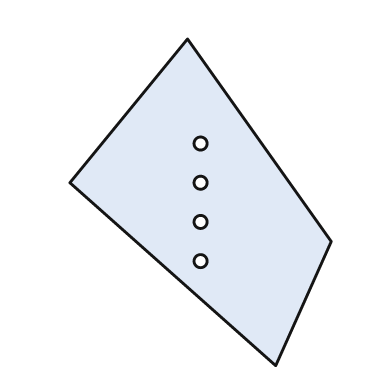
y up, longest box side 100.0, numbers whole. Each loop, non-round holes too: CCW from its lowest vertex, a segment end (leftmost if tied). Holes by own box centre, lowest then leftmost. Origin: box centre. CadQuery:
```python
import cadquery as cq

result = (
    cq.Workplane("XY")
    .moveTo(23.0, -50.0)
    .lineTo(40.0, -12.0)
    .lineTo(-4.0, 50.0)
    .lineTo(-40.0, 6.0)
    .close()
    .moveTo(0.0, -18.0)
    .circle(2.0)
    .moveTo(0.0, -6.0)
    .circle(2.0)
    .moveTo(0.0, 6.0)
    .circle(2.0)
    .moveTo(0.0, 18.0)
    .circle(2.0)
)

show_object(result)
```